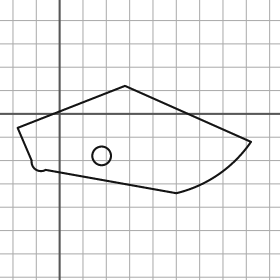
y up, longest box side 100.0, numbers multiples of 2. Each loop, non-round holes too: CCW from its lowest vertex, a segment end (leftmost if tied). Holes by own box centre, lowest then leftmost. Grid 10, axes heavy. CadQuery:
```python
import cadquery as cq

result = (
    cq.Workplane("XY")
    .moveTo(50.0, -34.0)
    .threePointArc((68.0, -26.0), (82.0, -12.0))
    .lineTo(28.0, 12.0)
    .lineTo(-18.0, -6.0)
    .lineTo(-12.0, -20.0)
    .threePointArc((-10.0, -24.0), (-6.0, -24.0))
    .close()
    .moveTo(18.0, -18.0)
    .circle(4.0)
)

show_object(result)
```